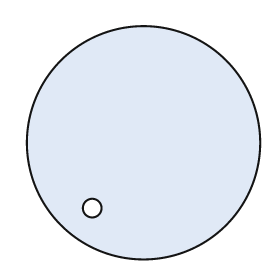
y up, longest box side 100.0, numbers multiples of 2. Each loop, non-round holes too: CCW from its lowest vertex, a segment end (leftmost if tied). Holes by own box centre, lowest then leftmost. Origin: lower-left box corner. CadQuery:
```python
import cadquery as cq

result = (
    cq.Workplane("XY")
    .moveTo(50.0, 50.0)
    .circle(50.0)
    .moveTo(28.0, 22.0)
    .circle(4.0)
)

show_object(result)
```